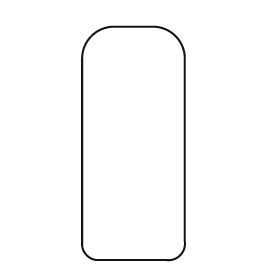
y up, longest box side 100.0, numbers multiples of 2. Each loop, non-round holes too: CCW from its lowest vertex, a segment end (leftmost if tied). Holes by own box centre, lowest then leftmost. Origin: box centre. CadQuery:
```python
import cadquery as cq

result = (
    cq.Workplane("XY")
    .moveTo(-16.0, -50.0)
    .lineTo(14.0, -50.0)
    .threePointArc((20.0, -48.0), (22.0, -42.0))
    .lineTo(22.0, 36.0)
    .threePointArc((18.0, 46.0), (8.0, 50.0))
    .lineTo(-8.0, 50.0)
    .threePointArc((-18.0, 46.0), (-22.0, 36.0))
    .lineTo(-22.0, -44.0)
    .threePointArc((-20.0, -48.0), (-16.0, -50.0))
    .close()
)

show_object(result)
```